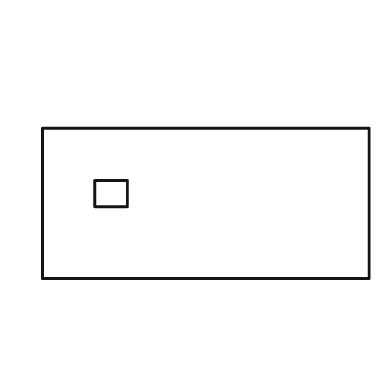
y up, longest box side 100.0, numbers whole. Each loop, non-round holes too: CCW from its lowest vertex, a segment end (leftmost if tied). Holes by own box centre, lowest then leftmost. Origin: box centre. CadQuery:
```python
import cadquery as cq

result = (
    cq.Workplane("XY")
    .moveTo(-50.0, -23.0)
    .lineTo(50.0, -23.0)
    .lineTo(50.0, 23.0)
    .lineTo(-50.0, 23.0)
    .close()
    .moveTo(-34.0, -1.0)
    .lineTo(-24.0, -1.0)
    .lineTo(-24.0, 7.0)
    .lineTo(-34.0, 7.0)
    .close()
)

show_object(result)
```